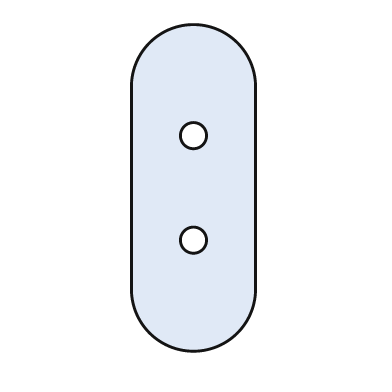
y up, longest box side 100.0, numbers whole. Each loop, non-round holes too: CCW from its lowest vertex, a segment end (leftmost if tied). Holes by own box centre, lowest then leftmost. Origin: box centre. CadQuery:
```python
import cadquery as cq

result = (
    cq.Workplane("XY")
    .moveTo(-19.0, -31.0)
    .threePointArc((0.0, -50.0), (19.0, -31.0))
    .lineTo(19.0, 31.0)
    .threePointArc((0.0, 50.0), (-19.0, 31.0))
    .close()
    .moveTo(0.0, -16.0)
    .circle(4.0)
    .moveTo(0.0, 16.0)
    .circle(4.0)
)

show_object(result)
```